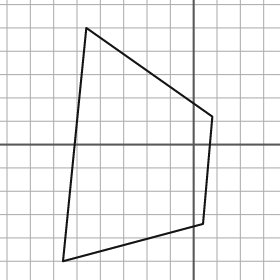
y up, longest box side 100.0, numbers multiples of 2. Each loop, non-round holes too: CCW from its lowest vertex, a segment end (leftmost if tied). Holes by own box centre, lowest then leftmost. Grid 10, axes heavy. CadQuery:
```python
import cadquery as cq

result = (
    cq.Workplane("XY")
    .moveTo(-56.0, -50.0)
    .lineTo(4.0, -34.0)
    .lineTo(8.0, 12.0)
    .lineTo(-46.0, 50.0)
    .close()
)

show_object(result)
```